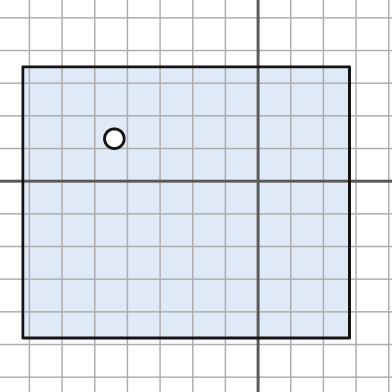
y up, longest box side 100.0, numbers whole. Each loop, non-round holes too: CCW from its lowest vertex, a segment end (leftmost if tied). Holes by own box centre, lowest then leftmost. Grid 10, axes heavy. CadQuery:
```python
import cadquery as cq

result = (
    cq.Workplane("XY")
    .moveTo(-72.0, -48.0)
    .lineTo(28.0, -48.0)
    .lineTo(28.0, 35.0)
    .lineTo(-72.0, 35.0)
    .close()
    .moveTo(-44.0, 13.0)
    .circle(3.0)
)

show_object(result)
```